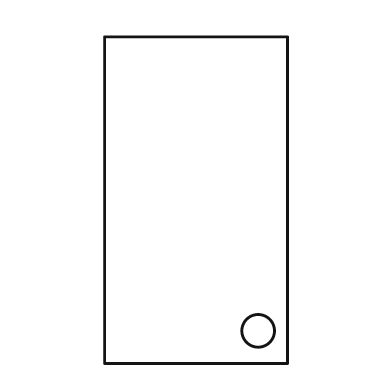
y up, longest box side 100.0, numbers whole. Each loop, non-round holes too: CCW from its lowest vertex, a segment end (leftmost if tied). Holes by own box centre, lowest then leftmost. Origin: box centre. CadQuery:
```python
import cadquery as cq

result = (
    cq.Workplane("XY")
    .moveTo(-28.0, -50.0)
    .lineTo(28.0, -50.0)
    .lineTo(28.0, 50.0)
    .lineTo(-28.0, 50.0)
    .close()
    .moveTo(19.0, -40.0)
    .circle(5.0)
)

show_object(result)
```